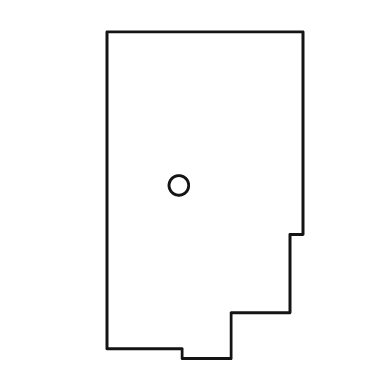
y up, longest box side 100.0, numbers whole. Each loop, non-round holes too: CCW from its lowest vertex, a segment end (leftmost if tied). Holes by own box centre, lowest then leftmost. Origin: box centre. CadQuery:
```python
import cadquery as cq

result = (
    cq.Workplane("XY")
    .moveTo(-7.0, -50.0)
    .lineTo(8.0, -50.0)
    .lineTo(8.0, -36.0)
    .lineTo(26.0, -36.0)
    .lineTo(26.0, -12.0)
    .lineTo(30.0, -12.0)
    .lineTo(30.0, 50.0)
    .lineTo(-30.0, 50.0)
    .lineTo(-30.0, -47.0)
    .lineTo(-7.0, -47.0)
    .close()
    .moveTo(-8.0, 3.0)
    .circle(3.0)
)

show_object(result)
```